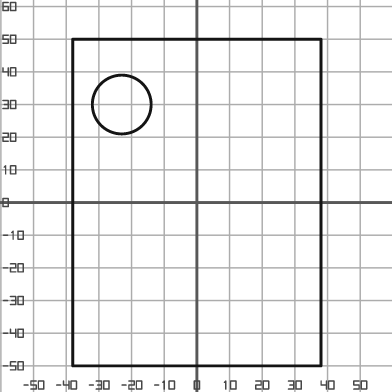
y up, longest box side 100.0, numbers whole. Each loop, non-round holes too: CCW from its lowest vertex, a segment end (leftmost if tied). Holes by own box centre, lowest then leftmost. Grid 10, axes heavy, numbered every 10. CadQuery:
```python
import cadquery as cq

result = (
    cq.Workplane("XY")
    .moveTo(-38.0, -50.0)
    .lineTo(38.0, -50.0)
    .lineTo(38.0, 50.0)
    .lineTo(-38.0, 50.0)
    .close()
    .moveTo(-23.0, 30.0)
    .circle(9.0)
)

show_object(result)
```